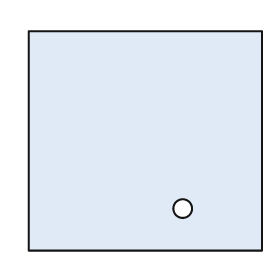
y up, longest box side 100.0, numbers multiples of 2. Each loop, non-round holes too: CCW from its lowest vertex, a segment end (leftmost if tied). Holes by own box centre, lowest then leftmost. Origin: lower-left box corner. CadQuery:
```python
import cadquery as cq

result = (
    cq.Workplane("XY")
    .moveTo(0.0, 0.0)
    .lineTo(100.0, 0.0)
    .lineTo(100.0, 94.0)
    .lineTo(0.0, 94.0)
    .close()
    .moveTo(66.0, 18.0)
    .circle(4.0)
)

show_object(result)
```